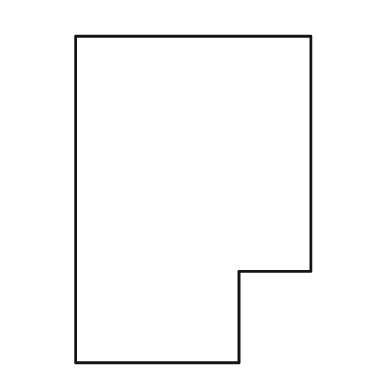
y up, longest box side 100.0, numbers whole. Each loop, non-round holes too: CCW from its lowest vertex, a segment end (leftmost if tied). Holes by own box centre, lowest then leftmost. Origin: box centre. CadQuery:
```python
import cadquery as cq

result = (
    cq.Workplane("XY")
    .moveTo(-36.0, -50.0)
    .lineTo(14.0, -50.0)
    .lineTo(14.0, -22.0)
    .lineTo(36.0, -22.0)
    .lineTo(36.0, 50.0)
    .lineTo(-36.0, 50.0)
    .close()
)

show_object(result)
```